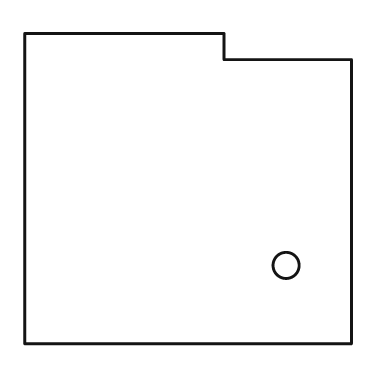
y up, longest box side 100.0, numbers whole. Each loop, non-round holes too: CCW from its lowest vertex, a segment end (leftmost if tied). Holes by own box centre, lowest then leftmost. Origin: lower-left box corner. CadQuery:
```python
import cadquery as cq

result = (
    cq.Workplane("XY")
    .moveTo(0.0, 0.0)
    .lineTo(100.0, 0.0)
    .lineTo(100.0, 87.0)
    .lineTo(61.0, 87.0)
    .lineTo(61.0, 95.0)
    .lineTo(0.0, 95.0)
    .close()
    .moveTo(80.0, 24.0)
    .circle(4.0)
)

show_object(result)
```